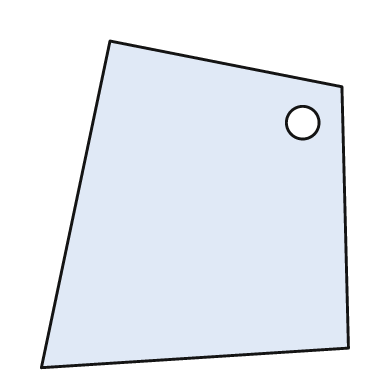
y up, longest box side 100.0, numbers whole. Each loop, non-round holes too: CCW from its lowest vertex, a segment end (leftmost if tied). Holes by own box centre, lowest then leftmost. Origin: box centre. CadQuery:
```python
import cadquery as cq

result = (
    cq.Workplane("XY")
    .moveTo(-47.0, -50.0)
    .lineTo(47.0, -44.0)
    .lineTo(45.0, 36.0)
    .lineTo(-26.0, 50.0)
    .close()
    .moveTo(33.0, 25.0)
    .circle(5.0)
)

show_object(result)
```